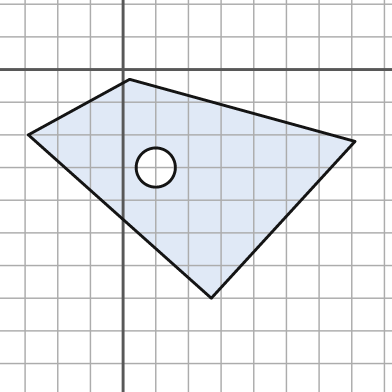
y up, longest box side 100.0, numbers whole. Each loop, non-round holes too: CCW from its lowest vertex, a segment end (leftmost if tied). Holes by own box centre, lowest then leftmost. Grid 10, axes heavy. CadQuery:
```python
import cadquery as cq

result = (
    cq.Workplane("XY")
    .moveTo(27.0, -70.0)
    .lineTo(71.0, -22.0)
    .lineTo(2.0, -3.0)
    .lineTo(-29.0, -20.0)
    .close()
    .moveTo(10.0, -30.0)
    .circle(6.0)
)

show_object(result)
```